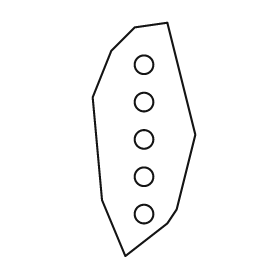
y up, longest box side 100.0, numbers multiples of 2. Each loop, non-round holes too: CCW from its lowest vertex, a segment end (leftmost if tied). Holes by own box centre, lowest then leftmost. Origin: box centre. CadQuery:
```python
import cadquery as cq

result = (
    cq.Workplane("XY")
    .moveTo(-8.0, -50.0)
    .lineTo(10.0, -36.0)
    .lineTo(14.0, -30.0)
    .lineTo(22.0, 2.0)
    .lineTo(10.0, 50.0)
    .lineTo(-4.0, 48.0)
    .lineTo(-14.0, 38.0)
    .lineTo(-22.0, 18.0)
    .lineTo(-18.0, -26.0)
    .close()
    .moveTo(0.0, -32.0)
    .circle(4.0)
    .moveTo(0.0, -16.0)
    .circle(4.0)
    .moveTo(0.0, 0.0)
    .circle(4.0)
    .moveTo(0.0, 16.0)
    .circle(4.0)
    .moveTo(0.0, 32.0)
    .circle(4.0)
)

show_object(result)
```